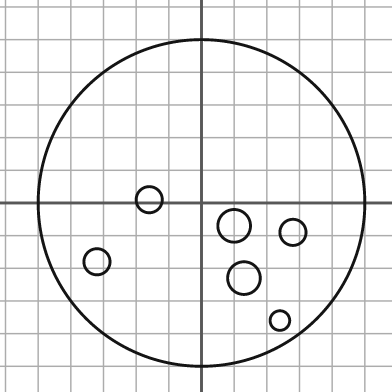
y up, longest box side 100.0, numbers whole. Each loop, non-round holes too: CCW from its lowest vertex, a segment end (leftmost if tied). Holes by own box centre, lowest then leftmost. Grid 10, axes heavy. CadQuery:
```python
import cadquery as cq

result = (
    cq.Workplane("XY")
    .moveTo(0.0, 0.0)
    .circle(50.0)
    .moveTo(24.0, -36.0)
    .circle(3.0)
    .moveTo(13.0, -23.0)
    .circle(5.0)
    .moveTo(-32.0, -18.0)
    .circle(4.0)
    .moveTo(28.0, -9.0)
    .circle(4.0)
    .moveTo(10.0, -7.0)
    .circle(5.0)
    .moveTo(-16.0, 1.0)
    .circle(4.0)
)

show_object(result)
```